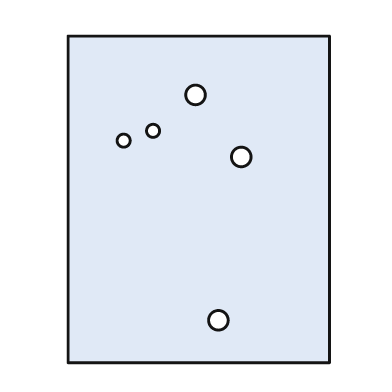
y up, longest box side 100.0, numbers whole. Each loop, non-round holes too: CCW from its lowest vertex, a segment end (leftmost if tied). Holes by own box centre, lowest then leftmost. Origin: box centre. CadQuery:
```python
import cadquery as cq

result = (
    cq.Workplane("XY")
    .moveTo(-40.0, -50.0)
    .lineTo(40.0, -50.0)
    .lineTo(40.0, 50.0)
    .lineTo(-40.0, 50.0)
    .close()
    .moveTo(6.0, -37.0)
    .circle(3.0)
    .moveTo(13.0, 13.0)
    .circle(3.0)
    .moveTo(-23.0, 18.0)
    .circle(2.0)
    .moveTo(-14.0, 21.0)
    .circle(2.0)
    .moveTo(-1.0, 32.0)
    .circle(3.0)
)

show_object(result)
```